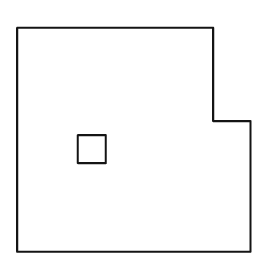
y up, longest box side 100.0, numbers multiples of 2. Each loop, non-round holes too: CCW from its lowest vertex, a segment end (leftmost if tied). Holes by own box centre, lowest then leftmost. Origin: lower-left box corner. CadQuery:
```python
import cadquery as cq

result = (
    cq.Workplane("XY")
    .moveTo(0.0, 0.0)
    .lineTo(100.0, 0.0)
    .lineTo(100.0, 56.0)
    .lineTo(84.0, 56.0)
    .lineTo(84.0, 96.0)
    .lineTo(0.0, 96.0)
    .close()
    .moveTo(26.0, 38.0)
    .lineTo(38.0, 38.0)
    .lineTo(38.0, 50.0)
    .lineTo(26.0, 50.0)
    .close()
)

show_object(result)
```